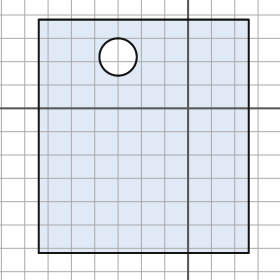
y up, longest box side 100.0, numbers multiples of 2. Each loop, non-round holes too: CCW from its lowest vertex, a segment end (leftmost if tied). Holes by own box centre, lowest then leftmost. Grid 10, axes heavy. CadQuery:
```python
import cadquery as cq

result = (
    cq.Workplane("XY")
    .moveTo(-64.0, -62.0)
    .lineTo(26.0, -62.0)
    .lineTo(26.0, 38.0)
    .lineTo(-64.0, 38.0)
    .close()
    .moveTo(-30.0, 22.0)
    .circle(8.0)
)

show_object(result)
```